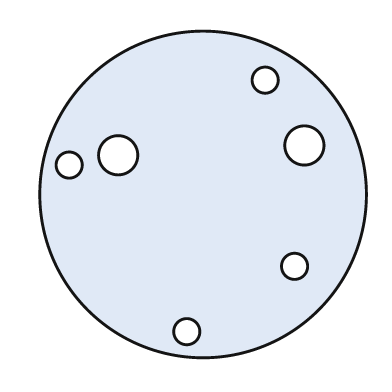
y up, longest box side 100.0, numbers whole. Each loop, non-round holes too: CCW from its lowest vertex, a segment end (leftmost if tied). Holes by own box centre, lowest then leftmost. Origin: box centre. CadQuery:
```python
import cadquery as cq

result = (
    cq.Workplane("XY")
    .moveTo(0.0, 0.0)
    .circle(50.0)
    .moveTo(-5.0, -42.0)
    .circle(4.0)
    .moveTo(28.0, -22.0)
    .circle(4.0)
    .moveTo(-41.0, 9.0)
    .circle(4.0)
    .moveTo(-26.0, 12.0)
    .circle(6.0)
    .moveTo(31.0, 15.0)
    .circle(6.0)
    .moveTo(19.0, 35.0)
    .circle(4.0)
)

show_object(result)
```